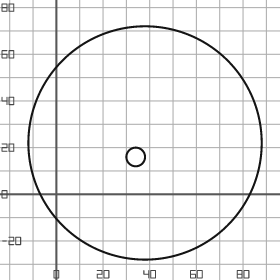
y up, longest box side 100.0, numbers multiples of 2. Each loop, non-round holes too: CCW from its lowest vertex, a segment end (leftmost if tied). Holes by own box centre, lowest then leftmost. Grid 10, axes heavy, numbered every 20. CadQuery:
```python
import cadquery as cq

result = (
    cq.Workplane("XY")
    .moveTo(38.0, 22.0)
    .circle(50.0)
    .moveTo(34.0, 16.0)
    .circle(4.0)
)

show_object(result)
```